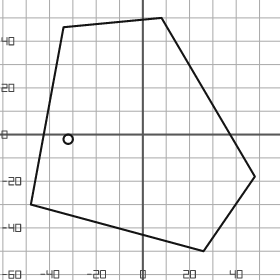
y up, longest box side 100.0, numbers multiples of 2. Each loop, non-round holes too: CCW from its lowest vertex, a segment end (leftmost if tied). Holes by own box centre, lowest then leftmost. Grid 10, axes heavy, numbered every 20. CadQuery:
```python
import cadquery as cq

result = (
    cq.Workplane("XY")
    .moveTo(26.0, -50.0)
    .lineTo(48.0, -18.0)
    .lineTo(8.0, 50.0)
    .lineTo(-34.0, 46.0)
    .lineTo(-48.0, -30.0)
    .close()
    .moveTo(-32.0, -2.0)
    .circle(2.0)
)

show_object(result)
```